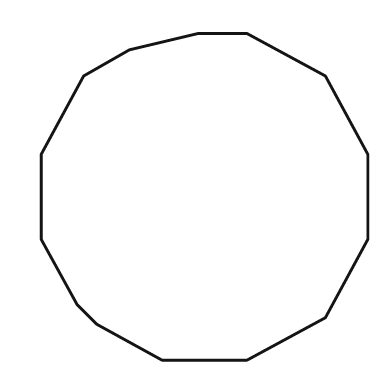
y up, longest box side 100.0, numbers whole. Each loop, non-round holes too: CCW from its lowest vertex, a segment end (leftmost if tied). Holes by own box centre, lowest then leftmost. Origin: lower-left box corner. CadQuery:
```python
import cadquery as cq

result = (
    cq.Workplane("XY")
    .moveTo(37.0, 0.0)
    .lineTo(63.0, 0.0)
    .lineTo(87.0, 13.0)
    .lineTo(100.0, 37.0)
    .lineTo(100.0, 63.0)
    .lineTo(87.0, 87.0)
    .lineTo(63.0, 100.0)
    .lineTo(48.0, 100.0)
    .lineTo(27.0, 95.0)
    .lineTo(13.0, 87.0)
    .lineTo(0.0, 63.0)
    .lineTo(0.0, 37.0)
    .lineTo(11.0, 17.0)
    .lineTo(17.0, 11.0)
    .close()
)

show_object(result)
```